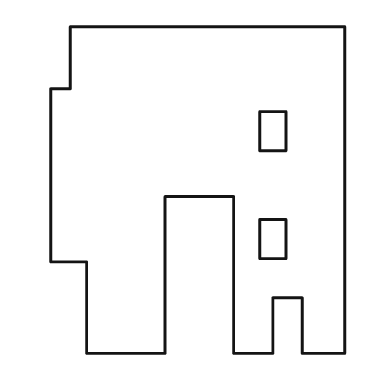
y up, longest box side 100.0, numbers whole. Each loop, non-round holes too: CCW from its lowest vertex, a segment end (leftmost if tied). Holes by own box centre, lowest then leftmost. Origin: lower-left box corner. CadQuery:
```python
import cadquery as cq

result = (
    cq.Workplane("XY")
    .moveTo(11.0, 0.0)
    .lineTo(35.0, 0.0)
    .lineTo(35.0, 48.0)
    .lineTo(56.0, 48.0)
    .lineTo(56.0, 0.0)
    .lineTo(68.0, 0.0)
    .lineTo(68.0, 17.0)
    .lineTo(77.0, 17.0)
    .lineTo(77.0, 0.0)
    .lineTo(90.0, 0.0)
    .lineTo(90.0, 100.0)
    .lineTo(6.0, 100.0)
    .lineTo(6.0, 81.0)
    .lineTo(0.0, 81.0)
    .lineTo(0.0, 28.0)
    .lineTo(11.0, 28.0)
    .close()
    .moveTo(64.0, 29.0)
    .lineTo(72.0, 29.0)
    .lineTo(72.0, 41.0)
    .lineTo(64.0, 41.0)
    .close()
    .moveTo(64.0, 62.0)
    .lineTo(72.0, 62.0)
    .lineTo(72.0, 74.0)
    .lineTo(64.0, 74.0)
    .close()
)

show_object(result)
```